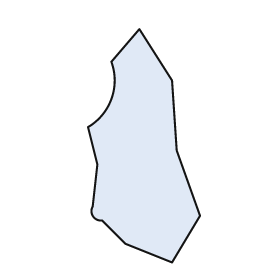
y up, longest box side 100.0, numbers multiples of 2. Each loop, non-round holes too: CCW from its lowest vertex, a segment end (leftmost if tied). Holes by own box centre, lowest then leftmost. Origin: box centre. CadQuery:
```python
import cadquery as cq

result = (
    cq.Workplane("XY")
    .moveTo(12.0, -50.0)
    .lineTo(24.0, -30.0)
    .lineTo(14.0, -2.0)
    .lineTo(12.0, 28.0)
    .lineTo(-2.0, 50.0)
    .lineTo(-14.0, 36.0)
    .threePointArc((-14.0, 20.0), (-24.0, 8.0))
    .lineTo(-20.0, -8.0)
    .lineTo(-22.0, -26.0)
    .threePointArc((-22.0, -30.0), (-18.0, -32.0))
    .lineTo(-8.0, -42.0)
    .close()
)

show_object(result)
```